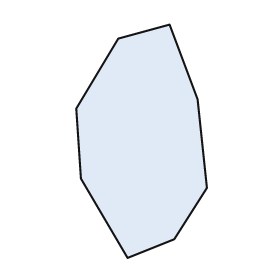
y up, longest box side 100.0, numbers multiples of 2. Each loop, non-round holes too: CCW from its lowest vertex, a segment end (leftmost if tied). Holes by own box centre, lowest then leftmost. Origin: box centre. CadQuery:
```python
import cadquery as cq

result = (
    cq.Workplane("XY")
    .moveTo(-6.0, -50.0)
    .lineTo(14.0, -42.0)
    .lineTo(28.0, -20.0)
    .lineTo(24.0, 18.0)
    .lineTo(12.0, 50.0)
    .lineTo(-10.0, 44.0)
    .lineTo(-28.0, 14.0)
    .lineTo(-26.0, -16.0)
    .close()
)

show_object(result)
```